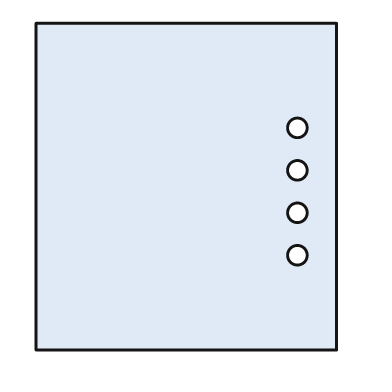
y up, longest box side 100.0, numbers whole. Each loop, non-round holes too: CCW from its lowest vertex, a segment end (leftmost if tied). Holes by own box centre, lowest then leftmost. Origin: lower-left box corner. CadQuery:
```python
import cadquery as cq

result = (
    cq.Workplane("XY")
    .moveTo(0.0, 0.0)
    .lineTo(92.0, 0.0)
    .lineTo(92.0, 100.0)
    .lineTo(0.0, 100.0)
    .close()
    .moveTo(80.0, 29.0)
    .circle(3.0)
    .moveTo(80.0, 42.0)
    .circle(3.0)
    .moveTo(80.0, 55.0)
    .circle(3.0)
    .moveTo(80.0, 68.0)
    .circle(3.0)
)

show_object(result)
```